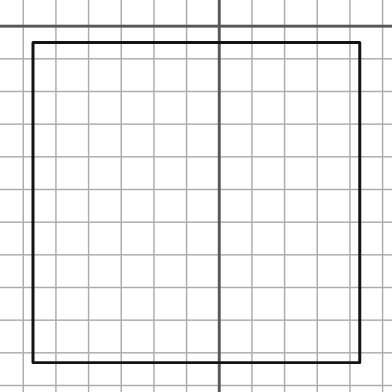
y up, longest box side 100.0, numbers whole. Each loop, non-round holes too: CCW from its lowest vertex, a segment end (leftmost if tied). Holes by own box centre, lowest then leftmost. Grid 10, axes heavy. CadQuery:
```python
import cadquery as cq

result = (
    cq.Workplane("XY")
    .moveTo(-57.0, -103.0)
    .lineTo(43.0, -103.0)
    .lineTo(43.0, -5.0)
    .lineTo(-57.0, -5.0)
    .close()
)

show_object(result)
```